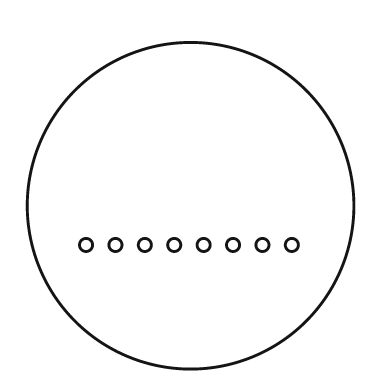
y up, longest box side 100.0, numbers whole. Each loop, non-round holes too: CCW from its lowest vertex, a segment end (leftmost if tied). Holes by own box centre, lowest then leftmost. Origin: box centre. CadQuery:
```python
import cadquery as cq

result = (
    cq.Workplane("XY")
    .moveTo(0.0, 0.0)
    .circle(50.0)
    .moveTo(-32.0, -12.0)
    .circle(2.0)
    .moveTo(-23.0, -12.0)
    .circle(2.0)
    .moveTo(-14.0, -12.0)
    .circle(2.0)
    .moveTo(-5.0, -12.0)
    .circle(2.0)
    .moveTo(4.0, -12.0)
    .circle(2.0)
    .moveTo(13.0, -12.0)
    .circle(2.0)
    .moveTo(22.0, -12.0)
    .circle(2.0)
    .moveTo(31.0, -12.0)
    .circle(2.0)
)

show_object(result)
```